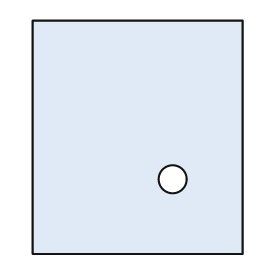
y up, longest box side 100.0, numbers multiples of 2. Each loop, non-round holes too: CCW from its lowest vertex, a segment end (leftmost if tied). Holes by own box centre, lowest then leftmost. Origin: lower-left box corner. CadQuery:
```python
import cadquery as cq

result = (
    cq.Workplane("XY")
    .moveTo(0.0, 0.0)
    .lineTo(90.0, 0.0)
    .lineTo(90.0, 100.0)
    .lineTo(0.0, 100.0)
    .close()
    .moveTo(60.0, 32.0)
    .circle(6.0)
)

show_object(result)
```